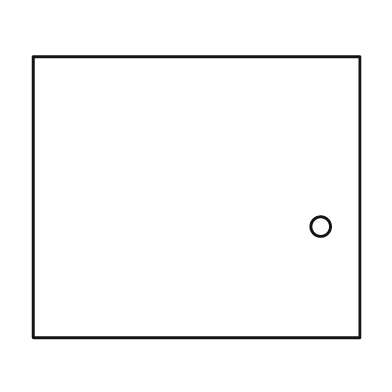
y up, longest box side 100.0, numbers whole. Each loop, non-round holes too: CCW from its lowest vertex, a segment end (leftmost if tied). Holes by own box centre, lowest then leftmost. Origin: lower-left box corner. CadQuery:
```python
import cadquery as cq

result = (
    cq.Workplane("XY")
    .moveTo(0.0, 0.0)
    .lineTo(100.0, 0.0)
    .lineTo(100.0, 86.0)
    .lineTo(0.0, 86.0)
    .close()
    .moveTo(88.0, 34.0)
    .circle(3.0)
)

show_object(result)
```